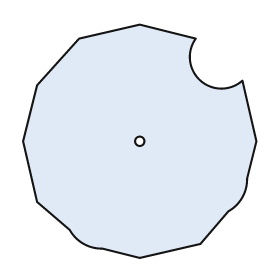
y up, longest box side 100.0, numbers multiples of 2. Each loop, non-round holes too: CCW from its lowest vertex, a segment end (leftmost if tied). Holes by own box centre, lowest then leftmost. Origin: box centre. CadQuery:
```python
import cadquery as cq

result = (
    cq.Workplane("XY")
    .moveTo(0.0, -50.0)
    .lineTo(26.0, -44.0)
    .lineTo(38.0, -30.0)
    .threePointArc((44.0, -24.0), (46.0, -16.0))
    .lineTo(50.0, 0.0)
    .lineTo(44.0, 26.0)
    .threePointArc((26.0, 26.0), (24.0, 44.0))
    .lineTo(0.0, 50.0)
    .lineTo(-26.0, 44.0)
    .lineTo(-44.0, 24.0)
    .lineTo(-50.0, 0.0)
    .lineTo(-44.0, -26.0)
    .lineTo(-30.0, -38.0)
    .threePointArc((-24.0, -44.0), (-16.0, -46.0))
    .close()
    .moveTo(0.0, 0.0)
    .circle(2.0)
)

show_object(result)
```